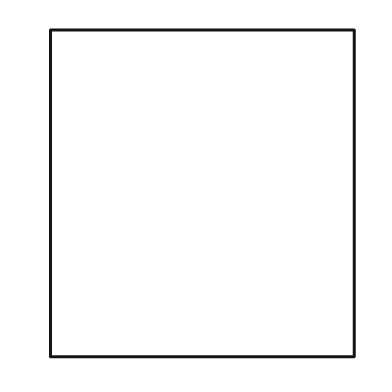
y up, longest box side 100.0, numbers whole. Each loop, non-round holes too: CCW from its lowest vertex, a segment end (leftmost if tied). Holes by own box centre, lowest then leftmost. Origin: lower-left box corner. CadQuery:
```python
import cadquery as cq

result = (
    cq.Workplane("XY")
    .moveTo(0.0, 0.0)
    .lineTo(93.0, 0.0)
    .lineTo(93.0, 100.0)
    .lineTo(0.0, 100.0)
    .close()
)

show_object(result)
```